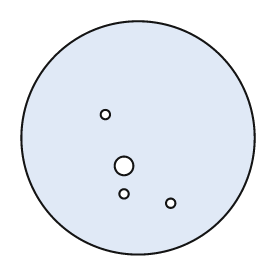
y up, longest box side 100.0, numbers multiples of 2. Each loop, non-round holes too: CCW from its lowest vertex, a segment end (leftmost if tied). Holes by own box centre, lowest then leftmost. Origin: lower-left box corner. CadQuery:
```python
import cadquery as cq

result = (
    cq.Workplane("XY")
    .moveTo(50.0, 50.0)
    .circle(50.0)
    .moveTo(64.0, 22.0)
    .circle(2.0)
    .moveTo(44.0, 26.0)
    .circle(2.0)
    .moveTo(44.0, 38.0)
    .circle(4.0)
    .moveTo(36.0, 60.0)
    .circle(2.0)
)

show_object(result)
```